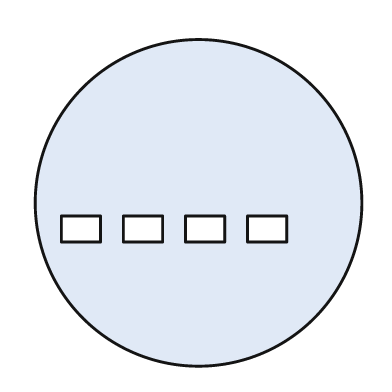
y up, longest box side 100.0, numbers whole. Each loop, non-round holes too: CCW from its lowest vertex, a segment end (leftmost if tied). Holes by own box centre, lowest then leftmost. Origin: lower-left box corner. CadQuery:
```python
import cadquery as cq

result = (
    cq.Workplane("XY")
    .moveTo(50.0, 50.0)
    .circle(50.0)
    .moveTo(8.0, 38.0)
    .lineTo(20.0, 38.0)
    .lineTo(20.0, 46.0)
    .lineTo(8.0, 46.0)
    .close()
    .moveTo(27.0, 38.0)
    .lineTo(39.0, 38.0)
    .lineTo(39.0, 46.0)
    .lineTo(27.0, 46.0)
    .close()
    .moveTo(46.0, 38.0)
    .lineTo(58.0, 38.0)
    .lineTo(58.0, 46.0)
    .lineTo(46.0, 46.0)
    .close()
    .moveTo(65.0, 38.0)
    .lineTo(77.0, 38.0)
    .lineTo(77.0, 46.0)
    .lineTo(65.0, 46.0)
    .close()
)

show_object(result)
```